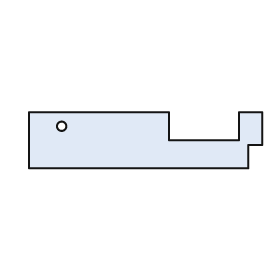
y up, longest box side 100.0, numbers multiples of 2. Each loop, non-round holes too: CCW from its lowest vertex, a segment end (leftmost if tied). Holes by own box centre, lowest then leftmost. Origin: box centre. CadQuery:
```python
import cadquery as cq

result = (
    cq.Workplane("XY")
    .moveTo(-50.0, -12.0)
    .lineTo(44.0, -12.0)
    .lineTo(44.0, -2.0)
    .lineTo(50.0, -2.0)
    .lineTo(50.0, 12.0)
    .lineTo(40.0, 12.0)
    .lineTo(40.0, 0.0)
    .lineTo(10.0, 0.0)
    .lineTo(10.0, 12.0)
    .lineTo(-50.0, 12.0)
    .close()
    .moveTo(-36.0, 6.0)
    .circle(2.0)
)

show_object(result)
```